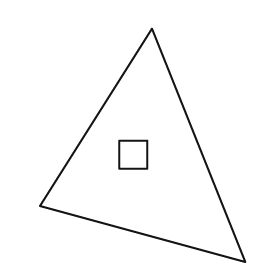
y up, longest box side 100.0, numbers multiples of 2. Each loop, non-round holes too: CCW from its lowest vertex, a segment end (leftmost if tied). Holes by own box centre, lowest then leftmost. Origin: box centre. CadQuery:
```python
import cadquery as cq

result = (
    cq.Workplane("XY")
    .moveTo(44.0, -50.0)
    .lineTo(4.0, 50.0)
    .lineTo(-44.0, -26.0)
    .close()
    .moveTo(-10.0, -10.0)
    .lineTo(2.0, -10.0)
    .lineTo(2.0, 2.0)
    .lineTo(-10.0, 2.0)
    .close()
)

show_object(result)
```